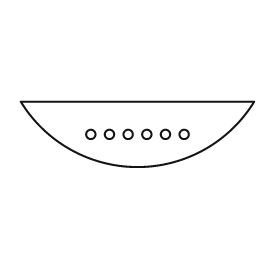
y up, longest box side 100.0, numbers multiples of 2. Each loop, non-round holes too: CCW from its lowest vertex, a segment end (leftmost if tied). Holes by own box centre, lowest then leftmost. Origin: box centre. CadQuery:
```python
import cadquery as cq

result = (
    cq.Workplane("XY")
    .moveTo(-50.0, 14.0)
    .threePointArc((0.0, -14.0), (50.0, 14.0))
    .close()
    .moveTo(-20.0, 0.0)
    .circle(2.0)
    .moveTo(-12.0, 0.0)
    .circle(2.0)
    .moveTo(-4.0, 0.0)
    .circle(2.0)
    .moveTo(4.0, 0.0)
    .circle(2.0)
    .moveTo(12.0, 0.0)
    .circle(2.0)
    .moveTo(20.0, 0.0)
    .circle(2.0)
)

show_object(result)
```